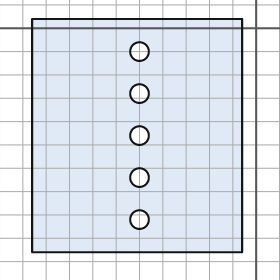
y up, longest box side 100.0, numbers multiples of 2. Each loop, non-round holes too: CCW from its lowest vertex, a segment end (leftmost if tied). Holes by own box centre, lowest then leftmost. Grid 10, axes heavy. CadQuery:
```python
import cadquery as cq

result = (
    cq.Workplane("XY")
    .moveTo(-96.0, -96.0)
    .lineTo(-6.0, -96.0)
    .lineTo(-6.0, 4.0)
    .lineTo(-96.0, 4.0)
    .close()
    .moveTo(-50.0, -82.0)
    .circle(4.0)
    .moveTo(-50.0, -64.0)
    .circle(4.0)
    .moveTo(-50.0, -46.0)
    .circle(4.0)
    .moveTo(-50.0, -28.0)
    .circle(4.0)
    .moveTo(-50.0, -10.0)
    .circle(4.0)
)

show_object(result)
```